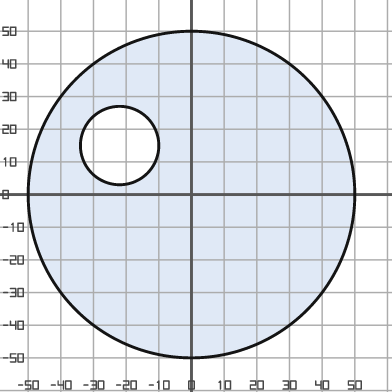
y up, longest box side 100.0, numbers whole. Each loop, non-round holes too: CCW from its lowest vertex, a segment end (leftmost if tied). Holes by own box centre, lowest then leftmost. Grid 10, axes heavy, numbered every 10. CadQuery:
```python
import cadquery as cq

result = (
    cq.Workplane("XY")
    .moveTo(0.0, 0.0)
    .circle(50.0)
    .moveTo(-22.0, 15.0)
    .circle(12.0)
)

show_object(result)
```